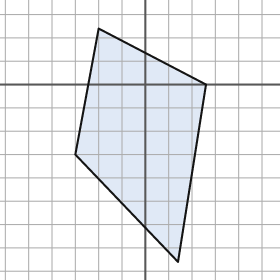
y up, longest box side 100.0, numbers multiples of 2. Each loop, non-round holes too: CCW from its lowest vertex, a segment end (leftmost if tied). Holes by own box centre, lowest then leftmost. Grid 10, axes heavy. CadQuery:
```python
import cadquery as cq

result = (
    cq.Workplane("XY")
    .moveTo(14.0, -76.0)
    .lineTo(26.0, 0.0)
    .lineTo(-20.0, 24.0)
    .lineTo(-30.0, -30.0)
    .close()
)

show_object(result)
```